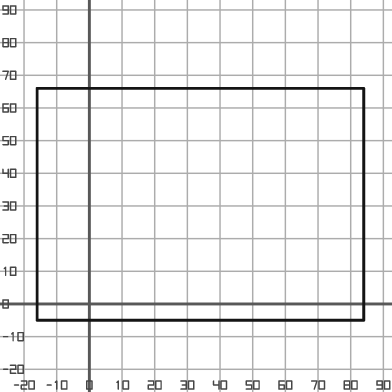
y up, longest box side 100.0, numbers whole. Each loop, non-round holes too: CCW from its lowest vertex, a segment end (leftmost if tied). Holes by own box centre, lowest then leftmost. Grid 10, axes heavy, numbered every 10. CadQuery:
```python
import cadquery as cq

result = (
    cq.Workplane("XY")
    .moveTo(-16.0, -5.0)
    .lineTo(84.0, -5.0)
    .lineTo(84.0, 66.0)
    .lineTo(-16.0, 66.0)
    .close()
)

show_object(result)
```